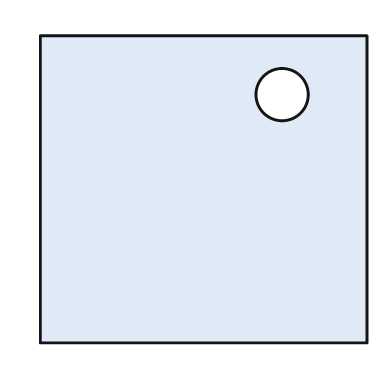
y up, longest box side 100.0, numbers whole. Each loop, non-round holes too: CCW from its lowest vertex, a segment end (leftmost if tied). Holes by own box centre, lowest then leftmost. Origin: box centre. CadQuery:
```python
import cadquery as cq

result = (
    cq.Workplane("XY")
    .moveTo(-50.0, -47.0)
    .lineTo(50.0, -47.0)
    .lineTo(50.0, 47.0)
    .lineTo(-50.0, 47.0)
    .close()
    .moveTo(24.0, 29.0)
    .circle(8.0)
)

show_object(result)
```